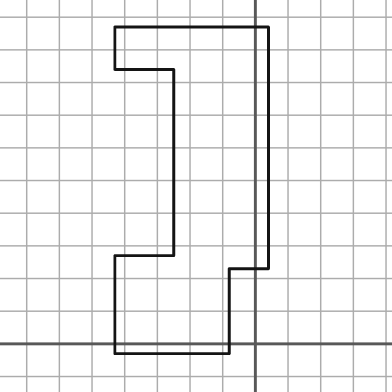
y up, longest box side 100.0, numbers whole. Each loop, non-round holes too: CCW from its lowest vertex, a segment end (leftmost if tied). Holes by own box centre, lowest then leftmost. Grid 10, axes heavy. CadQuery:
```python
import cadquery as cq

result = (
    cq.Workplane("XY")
    .moveTo(-43.0, -3.0)
    .lineTo(-8.0, -3.0)
    .lineTo(-8.0, 23.0)
    .lineTo(4.0, 23.0)
    .lineTo(4.0, 97.0)
    .lineTo(-43.0, 97.0)
    .lineTo(-43.0, 84.0)
    .lineTo(-25.0, 84.0)
    .lineTo(-25.0, 27.0)
    .lineTo(-43.0, 27.0)
    .close()
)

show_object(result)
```